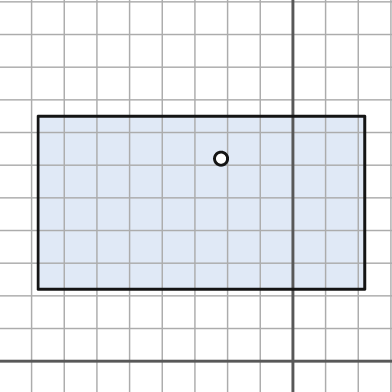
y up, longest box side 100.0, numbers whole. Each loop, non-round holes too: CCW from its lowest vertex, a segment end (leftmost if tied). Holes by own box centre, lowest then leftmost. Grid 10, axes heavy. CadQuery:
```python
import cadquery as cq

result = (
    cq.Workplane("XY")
    .moveTo(-78.0, 22.0)
    .lineTo(22.0, 22.0)
    .lineTo(22.0, 75.0)
    .lineTo(-78.0, 75.0)
    .close()
    .moveTo(-22.0, 62.0)
    .circle(2.0)
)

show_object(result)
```